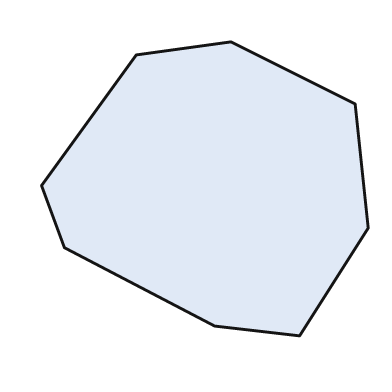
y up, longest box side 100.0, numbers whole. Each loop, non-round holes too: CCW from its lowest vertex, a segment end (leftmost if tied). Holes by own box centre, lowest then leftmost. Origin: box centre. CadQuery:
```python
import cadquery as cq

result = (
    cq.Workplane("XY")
    .moveTo(29.0, -45.0)
    .lineTo(50.0, -12.0)
    .lineTo(46.0, 26.0)
    .lineTo(8.0, 45.0)
    .lineTo(-21.0, 41.0)
    .lineTo(-50.0, 1.0)
    .lineTo(-43.0, -18.0)
    .lineTo(3.0, -42.0)
    .close()
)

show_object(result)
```